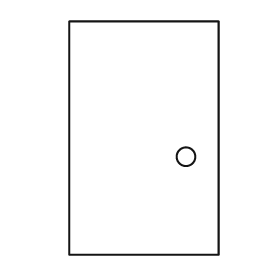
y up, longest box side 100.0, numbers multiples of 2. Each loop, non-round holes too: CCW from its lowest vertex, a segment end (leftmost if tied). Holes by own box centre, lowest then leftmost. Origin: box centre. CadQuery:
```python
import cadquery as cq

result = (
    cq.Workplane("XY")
    .moveTo(-32.0, -50.0)
    .lineTo(32.0, -50.0)
    .lineTo(32.0, 50.0)
    .lineTo(-32.0, 50.0)
    .close()
    .moveTo(18.0, -8.0)
    .circle(4.0)
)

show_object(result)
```